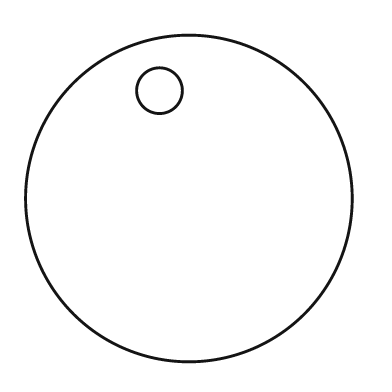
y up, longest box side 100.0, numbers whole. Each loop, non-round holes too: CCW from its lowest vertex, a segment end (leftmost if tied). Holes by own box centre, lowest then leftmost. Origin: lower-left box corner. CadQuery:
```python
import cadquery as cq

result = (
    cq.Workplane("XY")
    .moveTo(50.0, 50.0)
    .circle(50.0)
    .moveTo(41.0, 83.0)
    .circle(7.0)
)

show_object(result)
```